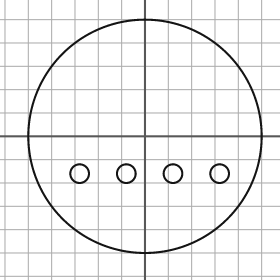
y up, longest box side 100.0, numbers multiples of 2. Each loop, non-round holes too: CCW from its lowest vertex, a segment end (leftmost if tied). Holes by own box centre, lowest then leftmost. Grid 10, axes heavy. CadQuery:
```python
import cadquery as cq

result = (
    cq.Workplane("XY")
    .moveTo(0.0, 0.0)
    .circle(50.0)
    .moveTo(-28.0, -16.0)
    .circle(4.0)
    .moveTo(-8.0, -16.0)
    .circle(4.0)
    .moveTo(12.0, -16.0)
    .circle(4.0)
    .moveTo(32.0, -16.0)
    .circle(4.0)
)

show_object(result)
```